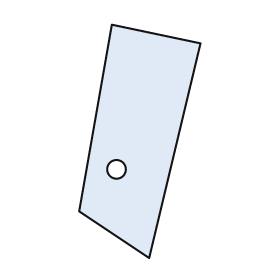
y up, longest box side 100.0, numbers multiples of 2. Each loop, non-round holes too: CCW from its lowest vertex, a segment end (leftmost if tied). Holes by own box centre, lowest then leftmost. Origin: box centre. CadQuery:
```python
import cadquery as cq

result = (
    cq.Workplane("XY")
    .moveTo(4.0, -50.0)
    .lineTo(26.0, 42.0)
    .lineTo(-12.0, 50.0)
    .lineTo(-26.0, -30.0)
    .close()
    .moveTo(-10.0, -12.0)
    .circle(4.0)
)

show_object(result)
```